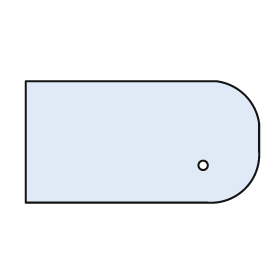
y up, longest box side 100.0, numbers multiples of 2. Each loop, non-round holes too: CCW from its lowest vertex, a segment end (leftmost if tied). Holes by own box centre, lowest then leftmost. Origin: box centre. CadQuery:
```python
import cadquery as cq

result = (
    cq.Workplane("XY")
    .moveTo(-50.0, -26.0)
    .lineTo(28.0, -26.0)
    .threePointArc((44.0, -20.0), (50.0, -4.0))
    .lineTo(50.0, 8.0)
    .threePointArc((44.0, 20.0), (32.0, 26.0))
    .lineTo(-50.0, 26.0)
    .close()
    .moveTo(26.0, -10.0)
    .circle(2.0)
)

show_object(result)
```